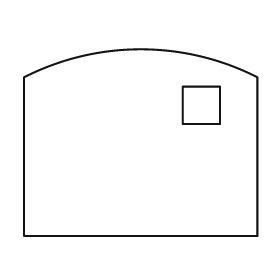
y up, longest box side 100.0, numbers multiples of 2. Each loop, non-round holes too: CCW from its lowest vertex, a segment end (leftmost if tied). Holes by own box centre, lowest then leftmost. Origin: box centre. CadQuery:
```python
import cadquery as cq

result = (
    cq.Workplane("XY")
    .moveTo(-50.0, -40.0)
    .lineTo(50.0, -40.0)
    .lineTo(50.0, 28.0)
    .threePointArc((0.0, 40.0), (-50.0, 28.0))
    .close()
    .moveTo(18.0, 8.0)
    .lineTo(34.0, 8.0)
    .lineTo(34.0, 24.0)
    .lineTo(18.0, 24.0)
    .close()
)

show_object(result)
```